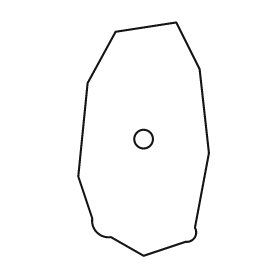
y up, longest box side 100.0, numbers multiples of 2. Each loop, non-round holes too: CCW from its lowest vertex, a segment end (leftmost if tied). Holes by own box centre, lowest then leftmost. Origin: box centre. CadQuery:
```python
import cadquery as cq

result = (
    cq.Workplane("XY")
    .moveTo(0.0, -50.0)
    .lineTo(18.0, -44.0)
    .threePointArc((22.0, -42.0), (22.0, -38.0))
    .lineTo(28.0, -6.0)
    .lineTo(24.0, 30.0)
    .lineTo(14.0, 50.0)
    .lineTo(-12.0, 46.0)
    .lineTo(-24.0, 24.0)
    .lineTo(-28.0, -16.0)
    .lineTo(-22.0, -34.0)
    .threePointArc((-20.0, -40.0), (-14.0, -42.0))
    .close()
    .moveTo(0.0, 0.0)
    .circle(4.0)
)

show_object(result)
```